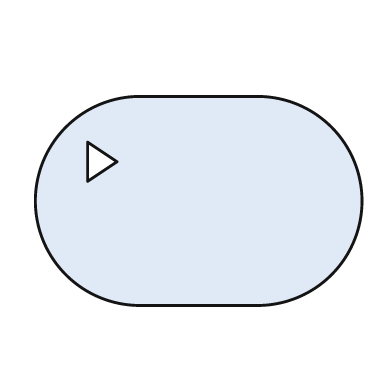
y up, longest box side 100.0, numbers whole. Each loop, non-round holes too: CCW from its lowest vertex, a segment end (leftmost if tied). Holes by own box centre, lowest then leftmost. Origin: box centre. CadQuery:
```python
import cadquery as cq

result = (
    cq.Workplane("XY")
    .moveTo(-18.0, -32.0)
    .lineTo(18.0, -32.0)
    .threePointArc((50.0, 0.0), (18.0, 32.0))
    .lineTo(-18.0, 32.0)
    .threePointArc((-50.0, 0.0), (-18.0, -32.0))
    .close()
    .moveTo(-34.0, 6.0)
    .lineTo(-25.0, 12.0)
    .lineTo(-34.0, 18.0)
    .close()
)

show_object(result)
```